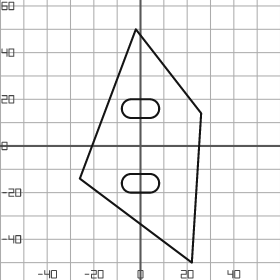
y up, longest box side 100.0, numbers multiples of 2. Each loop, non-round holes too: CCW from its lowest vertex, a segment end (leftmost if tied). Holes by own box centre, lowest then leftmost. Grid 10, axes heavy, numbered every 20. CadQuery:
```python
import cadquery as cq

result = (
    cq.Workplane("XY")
    .moveTo(22.0, -50.0)
    .lineTo(26.0, 14.0)
    .lineTo(-2.0, 50.0)
    .lineTo(-26.0, -14.0)
    .close()
    .moveTo(-4.0, -20.0)
    .lineTo(4.0, -20.0)
    .threePointArc((8.0, -16.0), (4.0, -12.0))
    .lineTo(-4.0, -12.0)
    .threePointArc((-8.0, -16.0), (-4.0, -20.0))
    .close()
    .moveTo(-4.0, 12.0)
    .lineTo(4.0, 12.0)
    .threePointArc((8.0, 16.0), (4.0, 20.0))
    .lineTo(-4.0, 20.0)
    .threePointArc((-8.0, 16.0), (-4.0, 12.0))
    .close()
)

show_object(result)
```